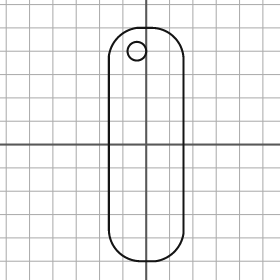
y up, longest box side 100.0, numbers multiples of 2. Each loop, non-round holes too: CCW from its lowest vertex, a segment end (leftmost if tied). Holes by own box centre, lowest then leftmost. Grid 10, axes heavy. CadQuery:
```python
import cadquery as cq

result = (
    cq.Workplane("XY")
    .moveTo(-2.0, -50.0)
    .lineTo(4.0, -50.0)
    .threePointArc((12.0, -46.0), (16.0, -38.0))
    .lineTo(16.0, 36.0)
    .threePointArc((12.0, 46.0), (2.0, 50.0))
    .lineTo(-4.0, 50.0)
    .threePointArc((-12.0, 46.0), (-16.0, 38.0))
    .lineTo(-16.0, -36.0)
    .threePointArc((-12.0, -46.0), (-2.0, -50.0))
    .close()
    .moveTo(-4.0, 40.0)
    .circle(4.0)
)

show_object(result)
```